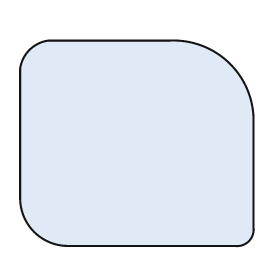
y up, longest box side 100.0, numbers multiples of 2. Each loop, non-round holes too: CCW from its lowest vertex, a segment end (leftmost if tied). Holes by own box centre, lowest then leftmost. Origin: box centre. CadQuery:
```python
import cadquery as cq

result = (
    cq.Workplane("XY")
    .moveTo(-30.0, -44.0)
    .lineTo(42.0, -44.0)
    .threePointArc((48.0, -42.0), (50.0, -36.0))
    .lineTo(50.0, 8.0)
    .threePointArc((40.0, 34.0), (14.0, 44.0))
    .lineTo(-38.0, 44.0)
    .threePointArc((-46.0, 40.0), (-50.0, 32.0))
    .lineTo(-50.0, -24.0)
    .threePointArc((-44.0, -38.0), (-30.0, -44.0))
    .close()
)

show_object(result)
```